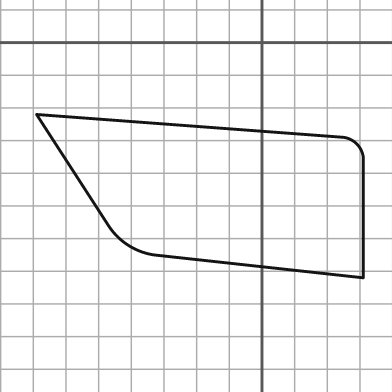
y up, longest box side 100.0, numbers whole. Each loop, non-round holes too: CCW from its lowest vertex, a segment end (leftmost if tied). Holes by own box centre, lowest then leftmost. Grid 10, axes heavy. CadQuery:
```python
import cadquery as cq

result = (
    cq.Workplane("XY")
    .moveTo(31.0, -72.0)
    .lineTo(31.0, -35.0)
    .threePointArc((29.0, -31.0), (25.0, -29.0))
    .lineTo(-69.0, -22.0)
    .lineTo(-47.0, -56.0)
    .threePointArc((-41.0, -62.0), (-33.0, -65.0))
    .close()
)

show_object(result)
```